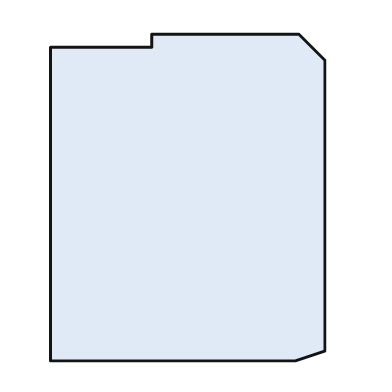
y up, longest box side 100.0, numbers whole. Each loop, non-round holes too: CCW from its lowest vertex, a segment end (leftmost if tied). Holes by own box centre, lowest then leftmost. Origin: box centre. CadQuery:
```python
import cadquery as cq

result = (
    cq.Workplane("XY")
    .moveTo(-42.0, -50.0)
    .lineTo(33.0, -50.0)
    .lineTo(42.0, -47.0)
    .lineTo(42.0, 42.0)
    .lineTo(34.0, 50.0)
    .lineTo(-11.0, 50.0)
    .lineTo(-11.0, 46.0)
    .lineTo(-42.0, 46.0)
    .close()
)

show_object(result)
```